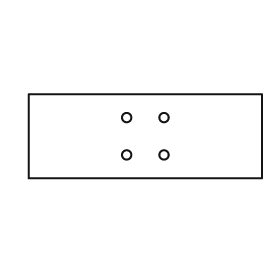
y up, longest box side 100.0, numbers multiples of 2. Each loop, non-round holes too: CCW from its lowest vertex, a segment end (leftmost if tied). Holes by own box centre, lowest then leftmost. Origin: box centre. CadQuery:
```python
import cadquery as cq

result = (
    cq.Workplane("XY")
    .moveTo(-50.0, -18.0)
    .lineTo(50.0, -18.0)
    .lineTo(50.0, 18.0)
    .lineTo(-50.0, 18.0)
    .close()
    .moveTo(-8.0, -8.0)
    .circle(2.0)
    .moveTo(8.0, -8.0)
    .circle(2.0)
    .moveTo(-8.0, 8.0)
    .circle(2.0)
    .moveTo(8.0, 8.0)
    .circle(2.0)
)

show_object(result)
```